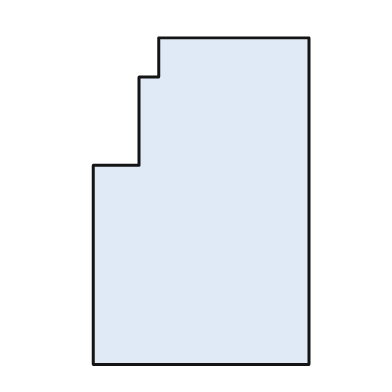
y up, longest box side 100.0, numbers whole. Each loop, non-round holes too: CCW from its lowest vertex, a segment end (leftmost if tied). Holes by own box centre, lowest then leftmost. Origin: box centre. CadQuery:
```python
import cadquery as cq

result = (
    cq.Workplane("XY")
    .moveTo(-33.0, -50.0)
    .lineTo(33.0, -50.0)
    .lineTo(33.0, 50.0)
    .lineTo(-13.0, 50.0)
    .lineTo(-13.0, 38.0)
    .lineTo(-19.0, 38.0)
    .lineTo(-19.0, 11.0)
    .lineTo(-33.0, 11.0)
    .close()
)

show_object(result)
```